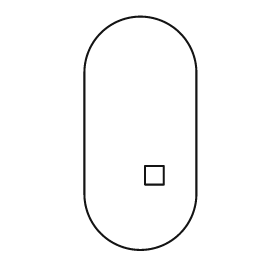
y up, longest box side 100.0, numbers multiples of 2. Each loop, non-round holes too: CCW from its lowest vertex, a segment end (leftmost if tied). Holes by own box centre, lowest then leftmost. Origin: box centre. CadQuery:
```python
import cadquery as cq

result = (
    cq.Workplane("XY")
    .moveTo(-24.0, -26.0)
    .threePointArc((0.0, -50.0), (24.0, -26.0))
    .lineTo(24.0, 26.0)
    .threePointArc((0.0, 50.0), (-24.0, 26.0))
    .close()
    .moveTo(2.0, -22.0)
    .lineTo(10.0, -22.0)
    .lineTo(10.0, -14.0)
    .lineTo(2.0, -14.0)
    .close()
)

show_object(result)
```